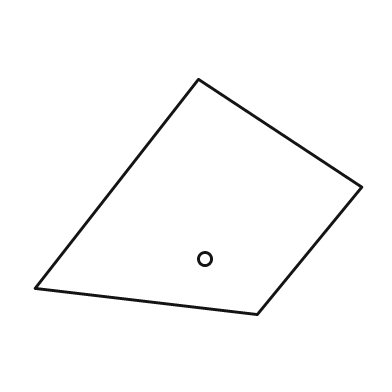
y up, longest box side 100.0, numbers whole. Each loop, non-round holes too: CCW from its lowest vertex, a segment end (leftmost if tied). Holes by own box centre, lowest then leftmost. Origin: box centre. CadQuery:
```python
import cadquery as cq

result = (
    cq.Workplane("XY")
    .moveTo(18.0, -36.0)
    .lineTo(50.0, 3.0)
    .lineTo(0.0, 36.0)
    .lineTo(-50.0, -28.0)
    .close()
    .moveTo(2.0, -19.0)
    .circle(2.0)
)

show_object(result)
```